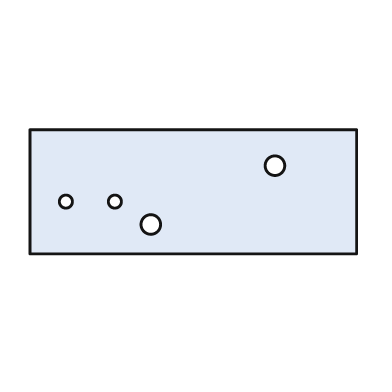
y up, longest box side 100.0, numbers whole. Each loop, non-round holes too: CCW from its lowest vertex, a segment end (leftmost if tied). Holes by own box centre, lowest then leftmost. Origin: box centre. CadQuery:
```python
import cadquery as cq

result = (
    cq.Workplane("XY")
    .moveTo(-50.0, -19.0)
    .lineTo(50.0, -19.0)
    .lineTo(50.0, 19.0)
    .lineTo(-50.0, 19.0)
    .close()
    .moveTo(-13.0, -10.0)
    .circle(3.0)
    .moveTo(-39.0, -3.0)
    .circle(2.0)
    .moveTo(-24.0, -3.0)
    .circle(2.0)
    .moveTo(25.0, 8.0)
    .circle(3.0)
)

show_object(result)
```